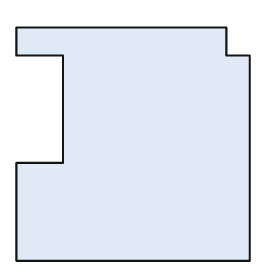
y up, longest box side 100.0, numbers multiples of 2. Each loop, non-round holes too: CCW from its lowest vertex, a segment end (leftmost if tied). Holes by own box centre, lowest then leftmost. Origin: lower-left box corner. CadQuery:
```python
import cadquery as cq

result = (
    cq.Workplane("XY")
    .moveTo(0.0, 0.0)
    .lineTo(100.0, 0.0)
    .lineTo(100.0, 88.0)
    .lineTo(90.0, 88.0)
    .lineTo(90.0, 100.0)
    .lineTo(0.0, 100.0)
    .lineTo(0.0, 88.0)
    .lineTo(20.0, 88.0)
    .lineTo(20.0, 42.0)
    .lineTo(0.0, 42.0)
    .close()
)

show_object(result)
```